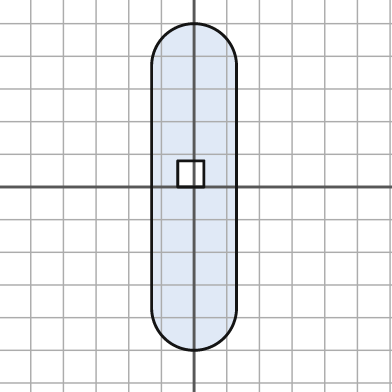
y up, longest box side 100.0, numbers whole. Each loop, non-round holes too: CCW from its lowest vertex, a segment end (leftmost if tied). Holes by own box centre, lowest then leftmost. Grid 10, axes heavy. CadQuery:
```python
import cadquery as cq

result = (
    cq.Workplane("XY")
    .moveTo(-13.0, -37.0)
    .threePointArc((0.0, -50.0), (13.0, -37.0))
    .lineTo(13.0, 37.0)
    .threePointArc((0.0, 50.0), (-13.0, 37.0))
    .close()
    .moveTo(-5.0, 0.0)
    .lineTo(3.0, 0.0)
    .lineTo(3.0, 8.0)
    .lineTo(-5.0, 8.0)
    .close()
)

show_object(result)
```